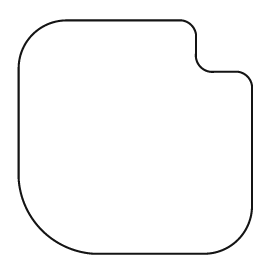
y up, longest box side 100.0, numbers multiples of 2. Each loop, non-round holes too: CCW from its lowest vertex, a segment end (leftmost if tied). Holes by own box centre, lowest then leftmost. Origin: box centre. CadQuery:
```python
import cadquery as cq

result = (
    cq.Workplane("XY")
    .moveTo(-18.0, -50.0)
    .lineTo(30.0, -50.0)
    .threePointArc((44.0, -44.0), (50.0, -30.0))
    .lineTo(50.0, 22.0)
    .threePointArc((48.0, 26.0), (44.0, 28.0))
    .lineTo(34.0, 28.0)
    .threePointArc((28.0, 30.0), (26.0, 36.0))
    .lineTo(26.0, 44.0)
    .threePointArc((24.0, 48.0), (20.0, 50.0))
    .lineTo(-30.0, 50.0)
    .threePointArc((-44.0, 44.0), (-50.0, 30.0))
    .lineTo(-50.0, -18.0)
    .threePointArc((-40.0, -40.0), (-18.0, -50.0))
    .close()
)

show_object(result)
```